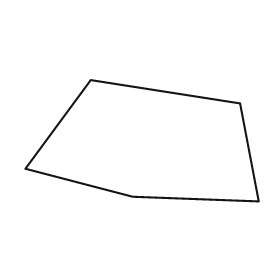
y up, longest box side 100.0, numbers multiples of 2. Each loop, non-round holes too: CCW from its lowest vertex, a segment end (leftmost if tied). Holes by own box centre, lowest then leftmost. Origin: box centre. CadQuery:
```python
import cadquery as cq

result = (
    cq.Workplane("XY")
    .moveTo(50.0, -26.0)
    .lineTo(42.0, 16.0)
    .lineTo(-22.0, 26.0)
    .lineTo(-50.0, -12.0)
    .lineTo(-4.0, -24.0)
    .close()
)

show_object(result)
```